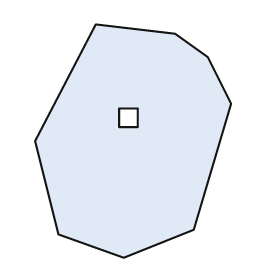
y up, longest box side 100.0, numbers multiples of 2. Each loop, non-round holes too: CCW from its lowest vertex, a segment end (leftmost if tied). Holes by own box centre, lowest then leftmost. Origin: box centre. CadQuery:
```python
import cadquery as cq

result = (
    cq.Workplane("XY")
    .moveTo(-4.0, -50.0)
    .lineTo(26.0, -38.0)
    .lineTo(42.0, 16.0)
    .lineTo(32.0, 36.0)
    .lineTo(18.0, 46.0)
    .lineTo(-16.0, 50.0)
    .lineTo(-42.0, 0.0)
    .lineTo(-32.0, -40.0)
    .close()
    .moveTo(-6.0, 6.0)
    .lineTo(2.0, 6.0)
    .lineTo(2.0, 14.0)
    .lineTo(-6.0, 14.0)
    .close()
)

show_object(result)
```